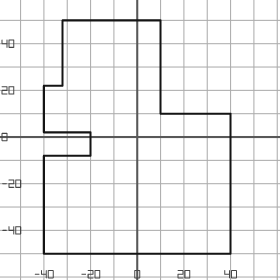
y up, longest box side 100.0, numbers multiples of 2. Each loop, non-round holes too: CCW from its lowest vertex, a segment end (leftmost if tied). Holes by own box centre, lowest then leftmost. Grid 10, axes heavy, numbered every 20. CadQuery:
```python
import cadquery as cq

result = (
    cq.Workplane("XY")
    .moveTo(-40.0, -50.0)
    .lineTo(40.0, -50.0)
    .lineTo(40.0, 10.0)
    .lineTo(10.0, 10.0)
    .lineTo(10.0, 50.0)
    .lineTo(-32.0, 50.0)
    .lineTo(-32.0, 22.0)
    .lineTo(-40.0, 22.0)
    .lineTo(-40.0, 2.0)
    .lineTo(-20.0, 2.0)
    .lineTo(-20.0, -8.0)
    .lineTo(-40.0, -8.0)
    .close()
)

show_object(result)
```